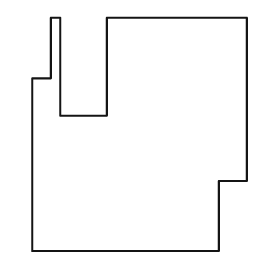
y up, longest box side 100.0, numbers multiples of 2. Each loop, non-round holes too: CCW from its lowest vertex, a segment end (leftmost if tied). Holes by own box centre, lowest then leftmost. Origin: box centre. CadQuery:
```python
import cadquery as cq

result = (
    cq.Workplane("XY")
    .moveTo(-46.0, -50.0)
    .lineTo(34.0, -50.0)
    .lineTo(34.0, -20.0)
    .lineTo(46.0, -20.0)
    .lineTo(46.0, 50.0)
    .lineTo(-14.0, 50.0)
    .lineTo(-14.0, 8.0)
    .lineTo(-34.0, 8.0)
    .lineTo(-34.0, 50.0)
    .lineTo(-38.0, 50.0)
    .lineTo(-38.0, 24.0)
    .lineTo(-46.0, 24.0)
    .close()
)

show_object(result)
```